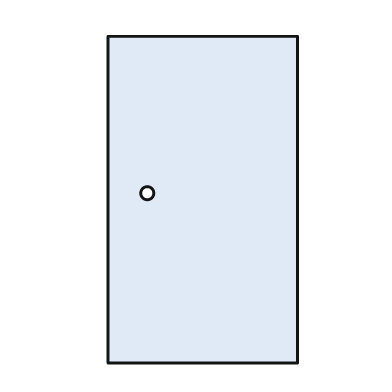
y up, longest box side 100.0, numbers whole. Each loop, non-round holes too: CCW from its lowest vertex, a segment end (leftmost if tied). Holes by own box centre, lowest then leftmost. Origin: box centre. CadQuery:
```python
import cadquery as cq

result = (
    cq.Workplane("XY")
    .moveTo(-29.0, -50.0)
    .lineTo(29.0, -50.0)
    .lineTo(29.0, 50.0)
    .lineTo(-29.0, 50.0)
    .close()
    .moveTo(-17.0, 2.0)
    .circle(2.0)
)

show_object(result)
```